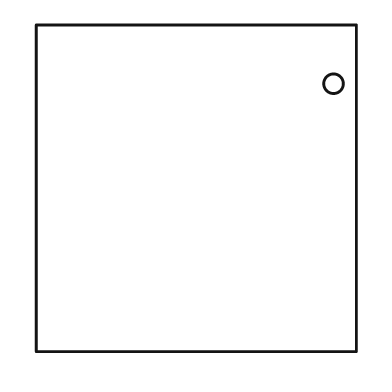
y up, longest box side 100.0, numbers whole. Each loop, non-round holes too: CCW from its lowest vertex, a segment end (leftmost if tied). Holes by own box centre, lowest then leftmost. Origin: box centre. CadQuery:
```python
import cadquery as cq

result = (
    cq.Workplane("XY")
    .moveTo(-49.0, -50.0)
    .lineTo(49.0, -50.0)
    .lineTo(49.0, 50.0)
    .lineTo(-49.0, 50.0)
    .close()
    .moveTo(42.0, 32.0)
    .circle(3.0)
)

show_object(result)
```